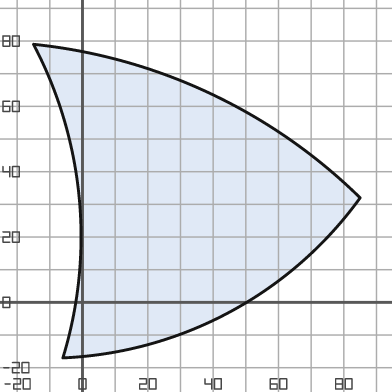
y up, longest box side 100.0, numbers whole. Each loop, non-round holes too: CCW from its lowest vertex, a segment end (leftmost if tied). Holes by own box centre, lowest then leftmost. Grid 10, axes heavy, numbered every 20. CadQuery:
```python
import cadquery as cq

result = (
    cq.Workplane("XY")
    .moveTo(-6.0, -17.0)
    .threePointArc((45.0, -3.0), (85.0, 32.0))
    .threePointArc((39.0, 64.0), (-15.0, 79.0))
    .threePointArc((-1.0, 32.0), (-6.0, -17.0))
    .close()
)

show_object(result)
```